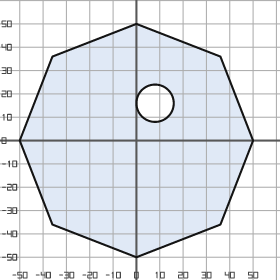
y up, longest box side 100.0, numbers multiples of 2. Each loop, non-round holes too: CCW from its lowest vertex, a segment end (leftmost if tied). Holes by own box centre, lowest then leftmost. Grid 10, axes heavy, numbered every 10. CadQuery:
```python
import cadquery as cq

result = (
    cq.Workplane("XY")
    .moveTo(0.0, -50.0)
    .lineTo(36.0, -36.0)
    .lineTo(50.0, 0.0)
    .lineTo(36.0, 36.0)
    .lineTo(0.0, 50.0)
    .lineTo(-36.0, 36.0)
    .lineTo(-50.0, 0.0)
    .lineTo(-36.0, -36.0)
    .close()
    .moveTo(8.0, 16.0)
    .circle(8.0)
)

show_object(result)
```